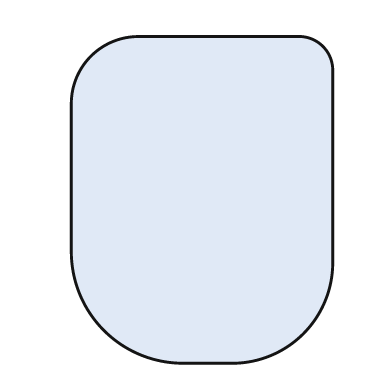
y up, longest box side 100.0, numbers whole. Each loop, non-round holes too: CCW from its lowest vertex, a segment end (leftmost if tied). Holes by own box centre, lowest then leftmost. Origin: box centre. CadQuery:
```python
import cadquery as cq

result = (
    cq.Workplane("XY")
    .moveTo(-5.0, -50.0)
    .lineTo(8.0, -50.0)
    .threePointArc((31.0, -41.0), (40.0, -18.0))
    .lineTo(40.0, 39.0)
    .threePointArc((37.0, 47.0), (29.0, 50.0))
    .lineTo(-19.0, 50.0)
    .threePointArc((-34.0, 44.0), (-40.0, 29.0))
    .lineTo(-40.0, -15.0)
    .threePointArc((-30.0, -40.0), (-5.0, -50.0))
    .close()
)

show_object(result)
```